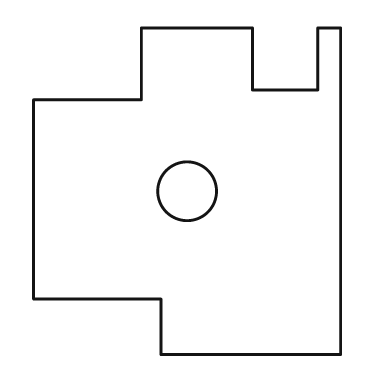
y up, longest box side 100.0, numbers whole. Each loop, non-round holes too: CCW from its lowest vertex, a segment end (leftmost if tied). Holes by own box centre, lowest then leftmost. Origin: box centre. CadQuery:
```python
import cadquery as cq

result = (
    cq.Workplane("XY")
    .moveTo(-8.0, -50.0)
    .lineTo(47.0, -50.0)
    .lineTo(47.0, 50.0)
    .lineTo(40.0, 50.0)
    .lineTo(40.0, 31.0)
    .lineTo(20.0, 31.0)
    .lineTo(20.0, 50.0)
    .lineTo(-14.0, 50.0)
    .lineTo(-14.0, 28.0)
    .lineTo(-47.0, 28.0)
    .lineTo(-47.0, -33.0)
    .lineTo(-8.0, -33.0)
    .close()
    .moveTo(0.0, 0.0)
    .circle(9.0)
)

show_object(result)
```